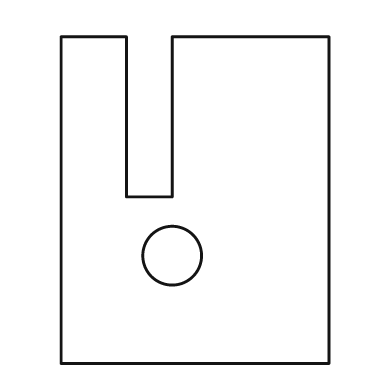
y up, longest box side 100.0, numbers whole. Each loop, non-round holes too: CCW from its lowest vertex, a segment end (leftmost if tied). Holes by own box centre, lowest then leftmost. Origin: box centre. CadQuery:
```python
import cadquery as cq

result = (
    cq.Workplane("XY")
    .moveTo(-41.0, -50.0)
    .lineTo(41.0, -50.0)
    .lineTo(41.0, 50.0)
    .lineTo(-7.0, 50.0)
    .lineTo(-7.0, 1.0)
    .lineTo(-21.0, 1.0)
    .lineTo(-21.0, 50.0)
    .lineTo(-41.0, 50.0)
    .close()
    .moveTo(-7.0, -17.0)
    .circle(9.0)
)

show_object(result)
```